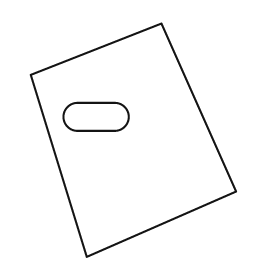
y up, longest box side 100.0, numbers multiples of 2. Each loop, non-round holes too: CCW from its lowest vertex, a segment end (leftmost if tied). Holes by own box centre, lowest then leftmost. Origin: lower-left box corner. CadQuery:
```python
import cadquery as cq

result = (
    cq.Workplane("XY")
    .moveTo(24.0, 0.0)
    .lineTo(88.0, 28.0)
    .lineTo(56.0, 100.0)
    .lineTo(0.0, 78.0)
    .close()
    .moveTo(20.0, 54.0)
    .lineTo(36.0, 54.0)
    .threePointArc((42.0, 60.0), (36.0, 66.0))
    .lineTo(20.0, 66.0)
    .threePointArc((14.0, 60.0), (20.0, 54.0))
    .close()
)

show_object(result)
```